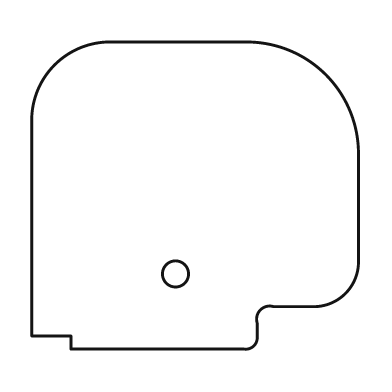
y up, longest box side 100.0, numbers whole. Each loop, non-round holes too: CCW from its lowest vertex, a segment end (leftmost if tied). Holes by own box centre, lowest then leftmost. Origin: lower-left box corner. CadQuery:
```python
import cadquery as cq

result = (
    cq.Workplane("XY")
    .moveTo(12.0, 0.0)
    .lineTo(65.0, 0.0)
    .threePointArc((68.0, 1.0), (69.0, 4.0))
    .lineTo(69.0, 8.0)
    .threePointArc((70.0, 12.0), (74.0, 13.0))
    .lineTo(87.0, 13.0)
    .threePointArc((96.0, 17.0), (100.0, 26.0))
    .lineTo(100.0, 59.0)
    .threePointArc((90.0, 84.0), (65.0, 94.0))
    .lineTo(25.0, 94.0)
    .threePointArc((7.0, 87.0), (0.0, 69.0))
    .lineTo(0.0, 4.0)
    .lineTo(12.0, 4.0)
    .close()
    .moveTo(44.0, 23.0)
    .circle(4.0)
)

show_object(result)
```